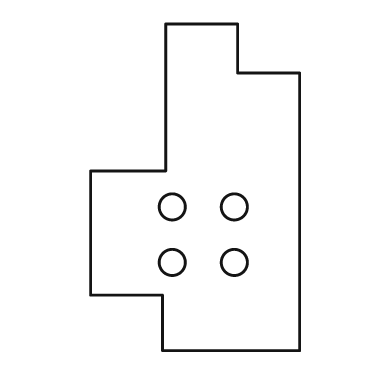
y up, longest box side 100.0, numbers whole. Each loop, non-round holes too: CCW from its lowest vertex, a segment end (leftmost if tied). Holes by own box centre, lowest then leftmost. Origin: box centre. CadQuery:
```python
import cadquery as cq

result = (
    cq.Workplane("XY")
    .moveTo(-10.0, -50.0)
    .lineTo(32.0, -50.0)
    .lineTo(32.0, 35.0)
    .lineTo(13.0, 35.0)
    .lineTo(13.0, 50.0)
    .lineTo(-9.0, 50.0)
    .lineTo(-9.0, 5.0)
    .lineTo(-32.0, 5.0)
    .lineTo(-32.0, -33.0)
    .lineTo(-10.0, -33.0)
    .close()
    .moveTo(-7.0, -23.0)
    .circle(4.0)
    .moveTo(12.0, -23.0)
    .circle(4.0)
    .moveTo(-7.0, -6.0)
    .circle(4.0)
    .moveTo(12.0, -6.0)
    .circle(4.0)
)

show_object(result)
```